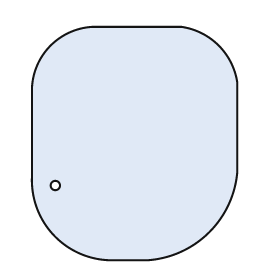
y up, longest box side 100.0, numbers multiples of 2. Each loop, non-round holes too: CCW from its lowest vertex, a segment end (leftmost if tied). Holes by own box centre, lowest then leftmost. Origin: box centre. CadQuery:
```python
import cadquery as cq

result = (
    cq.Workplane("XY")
    .moveTo(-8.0, -50.0)
    .lineTo(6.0, -50.0)
    .threePointArc((32.0, -38.0), (44.0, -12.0))
    .lineTo(44.0, 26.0)
    .threePointArc((36.0, 42.0), (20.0, 50.0))
    .lineTo(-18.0, 50.0)
    .threePointArc((-36.0, 42.0), (-44.0, 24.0))
    .lineTo(-44.0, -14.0)
    .threePointArc((-34.0, -40.0), (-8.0, -50.0))
    .close()
    .moveTo(-34.0, -18.0)
    .circle(2.0)
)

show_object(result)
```